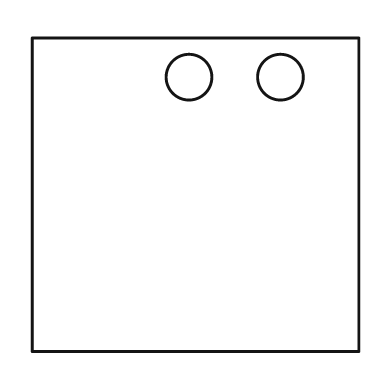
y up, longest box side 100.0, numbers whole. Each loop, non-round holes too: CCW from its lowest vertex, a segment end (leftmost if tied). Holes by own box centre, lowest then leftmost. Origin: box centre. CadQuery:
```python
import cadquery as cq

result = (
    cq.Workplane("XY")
    .moveTo(-50.0, -48.0)
    .lineTo(50.0, -48.0)
    .lineTo(50.0, 48.0)
    .lineTo(-50.0, 48.0)
    .close()
    .moveTo(-2.0, 36.0)
    .circle(7.0)
    .moveTo(26.0, 36.0)
    .circle(7.0)
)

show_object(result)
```